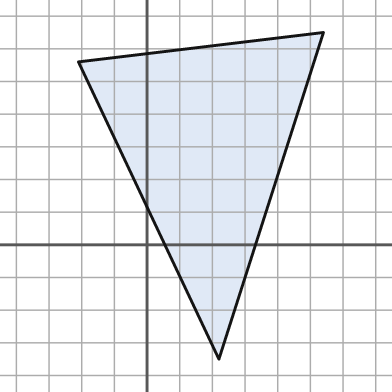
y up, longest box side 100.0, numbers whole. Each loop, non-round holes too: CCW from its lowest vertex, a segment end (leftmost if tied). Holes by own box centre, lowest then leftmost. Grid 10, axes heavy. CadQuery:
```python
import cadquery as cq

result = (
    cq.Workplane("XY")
    .moveTo(22.0, -35.0)
    .lineTo(54.0, 65.0)
    .lineTo(-21.0, 56.0)
    .close()
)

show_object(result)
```